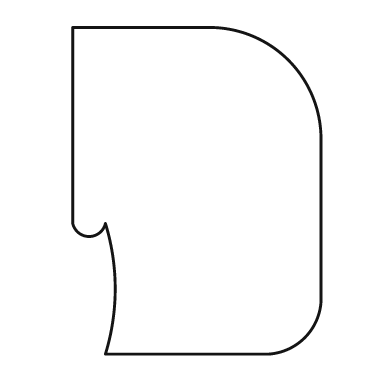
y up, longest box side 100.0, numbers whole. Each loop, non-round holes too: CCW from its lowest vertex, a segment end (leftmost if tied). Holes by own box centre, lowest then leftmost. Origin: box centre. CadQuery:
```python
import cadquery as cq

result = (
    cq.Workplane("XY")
    .moveTo(-28.0, -50.0)
    .lineTo(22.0, -50.0)
    .threePointArc((33.0, -45.0), (38.0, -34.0))
    .lineTo(38.0, 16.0)
    .threePointArc((28.0, 40.0), (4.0, 50.0))
    .lineTo(-38.0, 50.0)
    .lineTo(-38.0, -10.0)
    .threePointArc((-33.0, -14.0), (-28.0, -10.0))
    .threePointArc((-25.0, -30.0), (-28.0, -50.0))
    .close()
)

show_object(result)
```